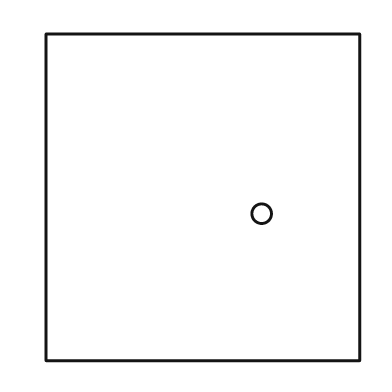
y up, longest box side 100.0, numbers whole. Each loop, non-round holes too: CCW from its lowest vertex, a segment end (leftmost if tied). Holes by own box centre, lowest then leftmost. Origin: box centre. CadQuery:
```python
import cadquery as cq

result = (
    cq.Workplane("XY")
    .moveTo(-48.0, -50.0)
    .lineTo(48.0, -50.0)
    .lineTo(48.0, 50.0)
    .lineTo(-48.0, 50.0)
    .close()
    .moveTo(18.0, -5.0)
    .circle(3.0)
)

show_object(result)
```